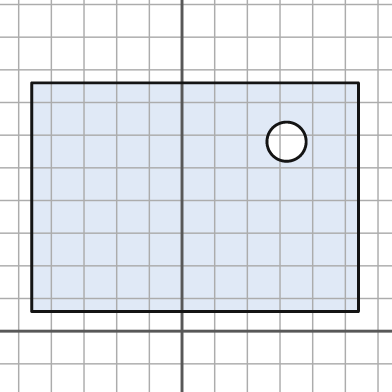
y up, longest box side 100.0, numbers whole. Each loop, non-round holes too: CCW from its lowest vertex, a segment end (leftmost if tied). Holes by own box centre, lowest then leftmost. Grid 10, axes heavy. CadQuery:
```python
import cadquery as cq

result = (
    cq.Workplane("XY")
    .moveTo(-46.0, 6.0)
    .lineTo(54.0, 6.0)
    .lineTo(54.0, 76.0)
    .lineTo(-46.0, 76.0)
    .close()
    .moveTo(32.0, 58.0)
    .circle(6.0)
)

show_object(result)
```